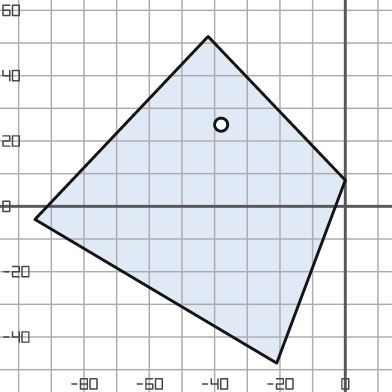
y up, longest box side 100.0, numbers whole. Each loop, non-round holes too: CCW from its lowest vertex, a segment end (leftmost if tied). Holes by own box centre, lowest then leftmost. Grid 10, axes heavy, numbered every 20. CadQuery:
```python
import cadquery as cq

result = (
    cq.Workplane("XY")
    .moveTo(-21.0, -48.0)
    .lineTo(0.0, 8.0)
    .lineTo(-42.0, 52.0)
    .lineTo(-95.0, -4.0)
    .close()
    .moveTo(-38.0, 25.0)
    .circle(2.0)
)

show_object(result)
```